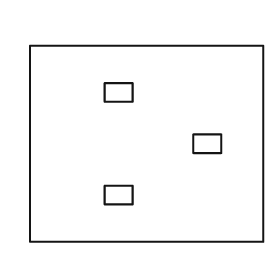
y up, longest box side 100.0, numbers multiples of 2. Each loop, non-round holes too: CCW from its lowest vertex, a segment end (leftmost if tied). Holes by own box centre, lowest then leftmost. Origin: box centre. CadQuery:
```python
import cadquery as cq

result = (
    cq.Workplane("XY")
    .moveTo(-50.0, -42.0)
    .lineTo(50.0, -42.0)
    .lineTo(50.0, 42.0)
    .lineTo(-50.0, 42.0)
    .close()
    .moveTo(-18.0, -26.0)
    .lineTo(-6.0, -26.0)
    .lineTo(-6.0, -18.0)
    .lineTo(-18.0, -18.0)
    .close()
    .moveTo(20.0, -4.0)
    .lineTo(32.0, -4.0)
    .lineTo(32.0, 4.0)
    .lineTo(20.0, 4.0)
    .close()
    .moveTo(-18.0, 18.0)
    .lineTo(-6.0, 18.0)
    .lineTo(-6.0, 26.0)
    .lineTo(-18.0, 26.0)
    .close()
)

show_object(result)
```